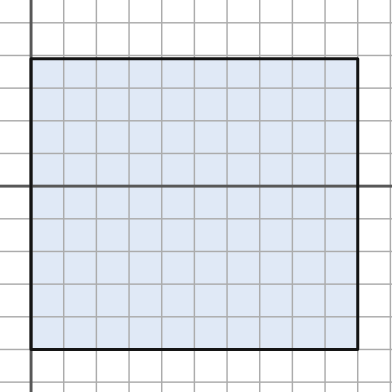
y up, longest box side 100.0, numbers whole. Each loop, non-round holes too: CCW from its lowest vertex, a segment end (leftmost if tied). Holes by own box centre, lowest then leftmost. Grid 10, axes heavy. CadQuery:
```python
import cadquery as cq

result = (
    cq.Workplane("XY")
    .moveTo(0.0, -50.0)
    .lineTo(100.0, -50.0)
    .lineTo(100.0, 39.0)
    .lineTo(0.0, 39.0)
    .close()
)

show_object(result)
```